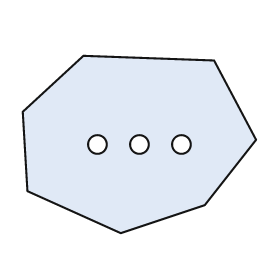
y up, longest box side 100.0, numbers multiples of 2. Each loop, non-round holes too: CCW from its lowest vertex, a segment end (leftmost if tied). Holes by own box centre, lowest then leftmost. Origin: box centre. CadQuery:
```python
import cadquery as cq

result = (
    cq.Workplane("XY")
    .moveTo(-8.0, -38.0)
    .lineTo(28.0, -26.0)
    .lineTo(50.0, 2.0)
    .lineTo(32.0, 36.0)
    .lineTo(-24.0, 38.0)
    .lineTo(-50.0, 14.0)
    .lineTo(-48.0, -20.0)
    .close()
    .moveTo(-18.0, 0.0)
    .circle(4.0)
    .moveTo(0.0, 0.0)
    .circle(4.0)
    .moveTo(18.0, 0.0)
    .circle(4.0)
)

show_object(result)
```